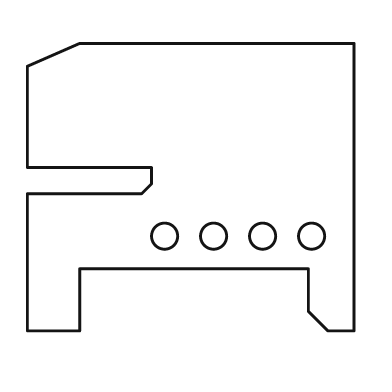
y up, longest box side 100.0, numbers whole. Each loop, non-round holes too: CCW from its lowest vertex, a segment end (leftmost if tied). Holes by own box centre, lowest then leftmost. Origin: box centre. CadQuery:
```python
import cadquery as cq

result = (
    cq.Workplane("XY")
    .moveTo(-50.0, -44.0)
    .lineTo(-34.0, -44.0)
    .lineTo(-34.0, -25.0)
    .lineTo(36.0, -25.0)
    .lineTo(36.0, -38.0)
    .lineTo(42.0, -44.0)
    .lineTo(50.0, -44.0)
    .lineTo(50.0, 44.0)
    .lineTo(-34.0, 44.0)
    .lineTo(-50.0, 37.0)
    .lineTo(-50.0, 6.0)
    .lineTo(-12.0, 6.0)
    .lineTo(-12.0, 1.0)
    .lineTo(-15.0, -2.0)
    .lineTo(-50.0, -2.0)
    .close()
    .moveTo(-8.0, -15.0)
    .circle(4.0)
    .moveTo(7.0, -15.0)
    .circle(4.0)
    .moveTo(22.0, -15.0)
    .circle(4.0)
    .moveTo(37.0, -15.0)
    .circle(4.0)
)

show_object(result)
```